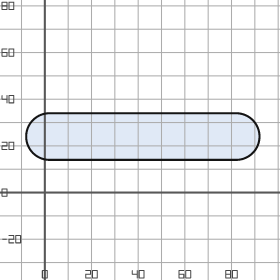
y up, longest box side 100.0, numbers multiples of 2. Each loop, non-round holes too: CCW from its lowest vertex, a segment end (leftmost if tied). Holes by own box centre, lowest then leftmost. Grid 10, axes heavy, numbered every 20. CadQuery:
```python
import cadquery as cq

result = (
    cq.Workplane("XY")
    .moveTo(2.0, 14.0)
    .lineTo(82.0, 14.0)
    .threePointArc((92.0, 24.0), (82.0, 34.0))
    .lineTo(2.0, 34.0)
    .threePointArc((-8.0, 24.0), (2.0, 14.0))
    .close()
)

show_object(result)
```